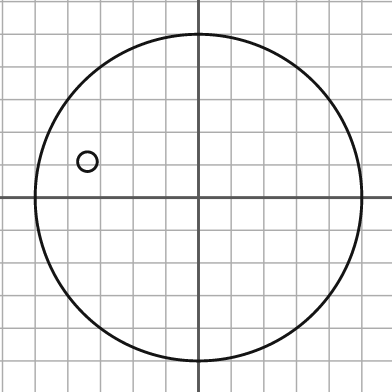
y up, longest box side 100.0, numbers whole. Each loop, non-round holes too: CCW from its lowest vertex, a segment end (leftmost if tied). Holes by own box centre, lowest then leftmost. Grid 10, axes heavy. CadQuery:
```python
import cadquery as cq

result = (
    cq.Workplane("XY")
    .moveTo(0.0, 0.0)
    .circle(50.0)
    .moveTo(-34.0, 11.0)
    .circle(3.0)
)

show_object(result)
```